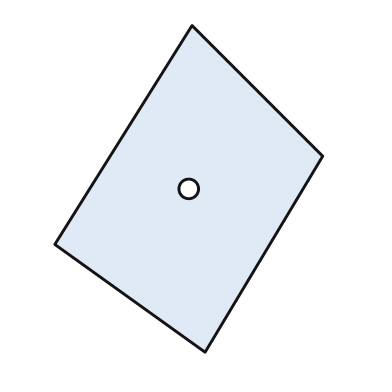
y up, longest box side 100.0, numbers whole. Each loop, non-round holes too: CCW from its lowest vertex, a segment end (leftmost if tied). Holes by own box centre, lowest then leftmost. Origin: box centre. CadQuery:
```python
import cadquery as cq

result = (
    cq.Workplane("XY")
    .moveTo(5.0, -50.0)
    .lineTo(41.0, 10.0)
    .lineTo(1.0, 50.0)
    .lineTo(-41.0, -17.0)
    .close()
    .moveTo(0.0, 0.0)
    .circle(3.0)
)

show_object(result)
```